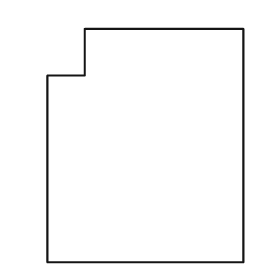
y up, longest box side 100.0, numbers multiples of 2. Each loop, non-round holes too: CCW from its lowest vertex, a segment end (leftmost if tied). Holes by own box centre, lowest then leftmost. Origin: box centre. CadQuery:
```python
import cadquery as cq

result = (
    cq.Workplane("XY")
    .moveTo(-42.0, -50.0)
    .lineTo(42.0, -50.0)
    .lineTo(42.0, 50.0)
    .lineTo(-26.0, 50.0)
    .lineTo(-26.0, 30.0)
    .lineTo(-42.0, 30.0)
    .close()
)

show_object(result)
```